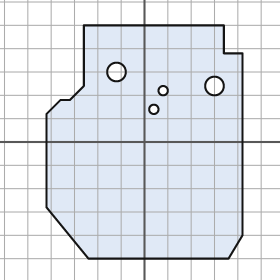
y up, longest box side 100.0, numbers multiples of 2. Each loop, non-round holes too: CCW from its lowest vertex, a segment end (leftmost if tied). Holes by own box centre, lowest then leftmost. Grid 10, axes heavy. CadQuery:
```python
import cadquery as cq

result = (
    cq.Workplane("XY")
    .moveTo(-24.0, -50.0)
    .lineTo(36.0, -50.0)
    .lineTo(42.0, -40.0)
    .lineTo(42.0, 38.0)
    .lineTo(34.0, 38.0)
    .lineTo(34.0, 50.0)
    .lineTo(-26.0, 50.0)
    .lineTo(-26.0, 24.0)
    .lineTo(-32.0, 18.0)
    .lineTo(-36.0, 18.0)
    .lineTo(-42.0, 12.0)
    .lineTo(-42.0, -28.0)
    .close()
    .moveTo(4.0, 14.0)
    .circle(2.0)
    .moveTo(8.0, 22.0)
    .circle(2.0)
    .moveTo(30.0, 24.0)
    .circle(4.0)
    .moveTo(-12.0, 30.0)
    .circle(4.0)
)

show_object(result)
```